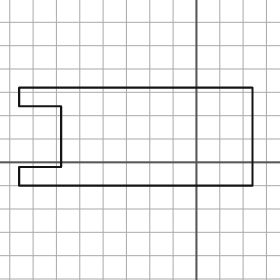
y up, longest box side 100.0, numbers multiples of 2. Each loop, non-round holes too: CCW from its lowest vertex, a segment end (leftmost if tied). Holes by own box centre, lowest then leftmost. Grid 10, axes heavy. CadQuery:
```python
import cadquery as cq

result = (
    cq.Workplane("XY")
    .moveTo(-76.0, -10.0)
    .lineTo(24.0, -10.0)
    .lineTo(24.0, 32.0)
    .lineTo(-76.0, 32.0)
    .lineTo(-76.0, 24.0)
    .lineTo(-58.0, 24.0)
    .lineTo(-58.0, -2.0)
    .lineTo(-76.0, -2.0)
    .close()
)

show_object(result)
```